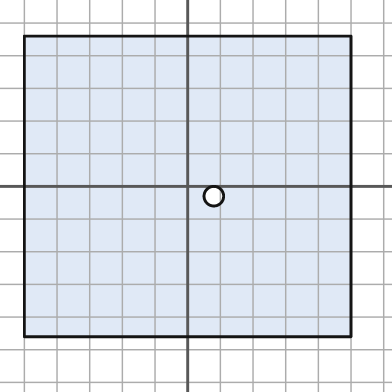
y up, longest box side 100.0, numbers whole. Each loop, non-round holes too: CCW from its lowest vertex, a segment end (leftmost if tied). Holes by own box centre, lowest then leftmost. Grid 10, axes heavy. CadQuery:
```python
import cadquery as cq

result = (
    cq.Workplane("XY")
    .moveTo(-50.0, -46.0)
    .lineTo(50.0, -46.0)
    .lineTo(50.0, 46.0)
    .lineTo(-50.0, 46.0)
    .close()
    .moveTo(8.0, -3.0)
    .circle(3.0)
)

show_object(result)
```